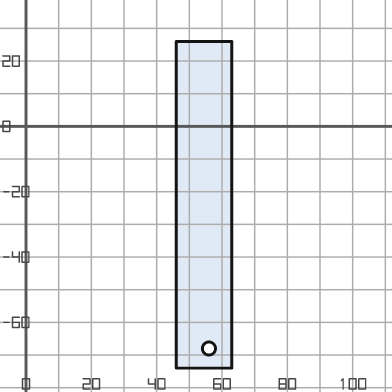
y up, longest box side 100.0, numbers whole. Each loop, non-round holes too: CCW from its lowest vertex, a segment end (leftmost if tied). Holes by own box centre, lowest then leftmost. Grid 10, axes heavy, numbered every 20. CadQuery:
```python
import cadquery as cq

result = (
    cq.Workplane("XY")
    .moveTo(46.0, -74.0)
    .lineTo(63.0, -74.0)
    .lineTo(63.0, 26.0)
    .lineTo(46.0, 26.0)
    .close()
    .moveTo(56.0, -68.0)
    .circle(2.0)
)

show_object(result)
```